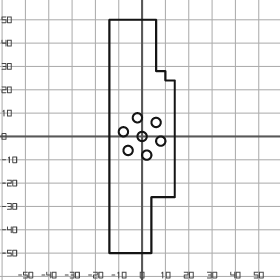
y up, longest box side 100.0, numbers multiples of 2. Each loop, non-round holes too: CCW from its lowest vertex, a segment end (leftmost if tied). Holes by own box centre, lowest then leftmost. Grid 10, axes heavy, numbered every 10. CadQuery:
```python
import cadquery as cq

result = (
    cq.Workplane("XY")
    .moveTo(-14.0, -50.0)
    .lineTo(4.0, -50.0)
    .lineTo(4.0, -26.0)
    .lineTo(14.0, -26.0)
    .lineTo(14.0, 24.0)
    .lineTo(10.0, 24.0)
    .lineTo(10.0, 28.0)
    .lineTo(6.0, 28.0)
    .lineTo(6.0, 50.0)
    .lineTo(-14.0, 50.0)
    .close()
    .moveTo(2.0, -8.0)
    .circle(2.0)
    .moveTo(-6.0, -6.0)
    .circle(2.0)
    .moveTo(8.0, -2.0)
    .circle(2.0)
    .moveTo(0.0, 0.0)
    .circle(2.0)
    .moveTo(-8.0, 2.0)
    .circle(2.0)
    .moveTo(6.0, 6.0)
    .circle(2.0)
    .moveTo(-2.0, 8.0)
    .circle(2.0)
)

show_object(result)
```